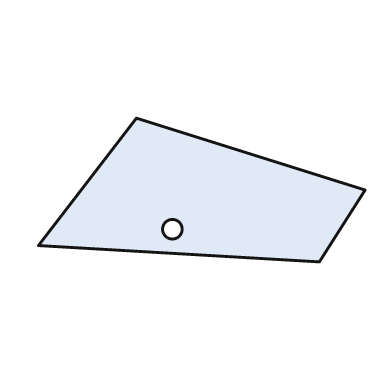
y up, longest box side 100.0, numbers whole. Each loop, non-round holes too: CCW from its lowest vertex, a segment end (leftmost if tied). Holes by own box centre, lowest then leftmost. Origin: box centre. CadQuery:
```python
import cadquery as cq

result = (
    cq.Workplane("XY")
    .moveTo(36.0, -22.0)
    .lineTo(50.0, 0.0)
    .lineTo(-20.0, 22.0)
    .lineTo(-50.0, -17.0)
    .close()
    .moveTo(-9.0, -12.0)
    .circle(3.0)
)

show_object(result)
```